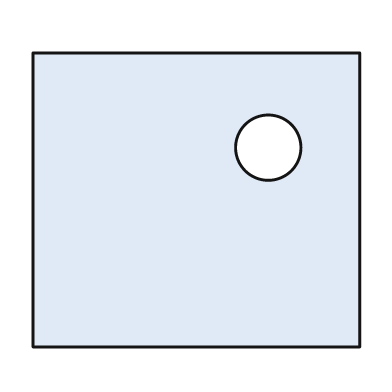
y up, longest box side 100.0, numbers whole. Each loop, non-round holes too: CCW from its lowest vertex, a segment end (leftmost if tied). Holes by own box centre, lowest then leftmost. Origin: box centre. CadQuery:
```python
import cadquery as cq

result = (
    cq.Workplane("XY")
    .moveTo(-50.0, -45.0)
    .lineTo(50.0, -45.0)
    .lineTo(50.0, 45.0)
    .lineTo(-50.0, 45.0)
    .close()
    .moveTo(22.0, 16.0)
    .circle(10.0)
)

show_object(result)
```